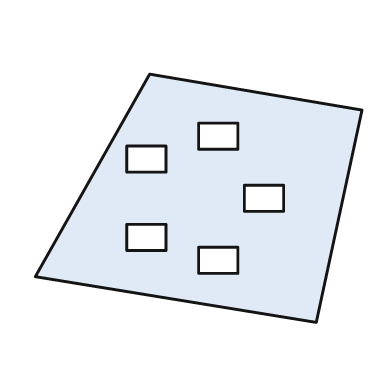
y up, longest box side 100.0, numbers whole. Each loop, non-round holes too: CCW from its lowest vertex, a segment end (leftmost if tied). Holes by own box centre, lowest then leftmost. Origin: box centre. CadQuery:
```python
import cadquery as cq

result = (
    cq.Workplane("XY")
    .moveTo(36.0, -38.0)
    .lineTo(50.0, 27.0)
    .lineTo(-15.0, 38.0)
    .lineTo(-50.0, -24.0)
    .close()
    .moveTo(0.0, -23.0)
    .lineTo(12.0, -23.0)
    .lineTo(12.0, -15.0)
    .lineTo(0.0, -15.0)
    .close()
    .moveTo(-22.0, -16.0)
    .lineTo(-10.0, -16.0)
    .lineTo(-10.0, -8.0)
    .lineTo(-22.0, -8.0)
    .close()
    .moveTo(14.0, -4.0)
    .lineTo(26.0, -4.0)
    .lineTo(26.0, 4.0)
    .lineTo(14.0, 4.0)
    .close()
    .moveTo(-22.0, 8.0)
    .lineTo(-10.0, 8.0)
    .lineTo(-10.0, 16.0)
    .lineTo(-22.0, 16.0)
    .close()
    .moveTo(0.0, 15.0)
    .lineTo(12.0, 15.0)
    .lineTo(12.0, 23.0)
    .lineTo(0.0, 23.0)
    .close()
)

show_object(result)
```